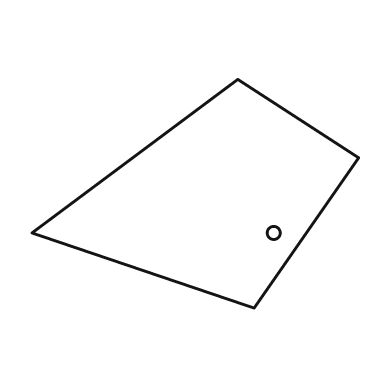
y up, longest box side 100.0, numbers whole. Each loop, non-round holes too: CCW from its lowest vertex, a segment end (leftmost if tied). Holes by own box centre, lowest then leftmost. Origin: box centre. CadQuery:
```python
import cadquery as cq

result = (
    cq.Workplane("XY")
    .moveTo(18.0, -35.0)
    .lineTo(50.0, 11.0)
    .lineTo(13.0, 35.0)
    .lineTo(-50.0, -12.0)
    .close()
    .moveTo(24.0, -12.0)
    .circle(2.0)
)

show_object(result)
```